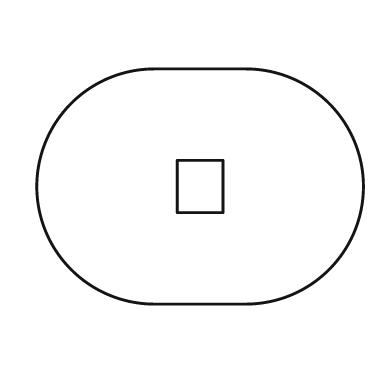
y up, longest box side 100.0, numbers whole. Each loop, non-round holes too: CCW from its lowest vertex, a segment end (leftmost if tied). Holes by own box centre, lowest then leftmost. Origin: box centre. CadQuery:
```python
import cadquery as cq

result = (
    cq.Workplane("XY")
    .moveTo(-14.0, -36.0)
    .lineTo(14.0, -36.0)
    .threePointArc((50.0, 0.0), (14.0, 36.0))
    .lineTo(-14.0, 36.0)
    .threePointArc((-50.0, 0.0), (-14.0, -36.0))
    .close()
    .moveTo(-7.0, -8.0)
    .lineTo(7.0, -8.0)
    .lineTo(7.0, 8.0)
    .lineTo(-7.0, 8.0)
    .close()
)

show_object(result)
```